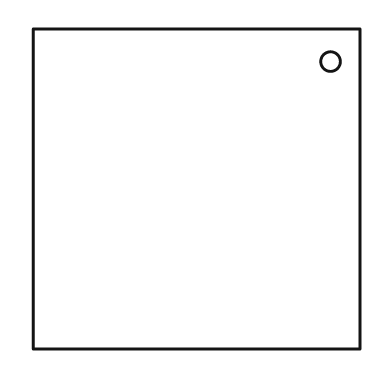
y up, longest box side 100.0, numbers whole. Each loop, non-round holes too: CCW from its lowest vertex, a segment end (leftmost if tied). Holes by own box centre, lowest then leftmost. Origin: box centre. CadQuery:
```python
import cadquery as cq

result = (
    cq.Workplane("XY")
    .moveTo(-50.0, -49.0)
    .lineTo(50.0, -49.0)
    .lineTo(50.0, 49.0)
    .lineTo(-50.0, 49.0)
    .close()
    .moveTo(41.0, 39.0)
    .circle(3.0)
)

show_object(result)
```